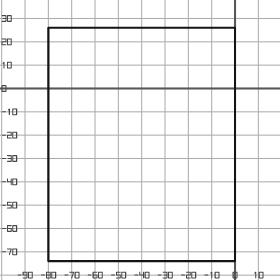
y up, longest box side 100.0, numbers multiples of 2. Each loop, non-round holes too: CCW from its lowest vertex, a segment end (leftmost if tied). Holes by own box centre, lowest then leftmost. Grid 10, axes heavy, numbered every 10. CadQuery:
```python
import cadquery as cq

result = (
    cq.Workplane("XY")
    .moveTo(-80.0, -74.0)
    .lineTo(0.0, -74.0)
    .lineTo(0.0, 26.0)
    .lineTo(-80.0, 26.0)
    .close()
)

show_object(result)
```